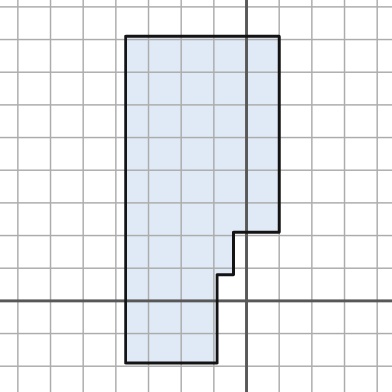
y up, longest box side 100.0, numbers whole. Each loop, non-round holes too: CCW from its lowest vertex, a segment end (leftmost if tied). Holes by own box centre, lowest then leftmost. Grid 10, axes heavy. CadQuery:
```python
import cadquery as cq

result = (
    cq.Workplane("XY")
    .moveTo(-37.0, -19.0)
    .lineTo(-9.0, -19.0)
    .lineTo(-9.0, 8.0)
    .lineTo(-4.0, 8.0)
    .lineTo(-4.0, 21.0)
    .lineTo(10.0, 21.0)
    .lineTo(10.0, 81.0)
    .lineTo(-37.0, 81.0)
    .close()
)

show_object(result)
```